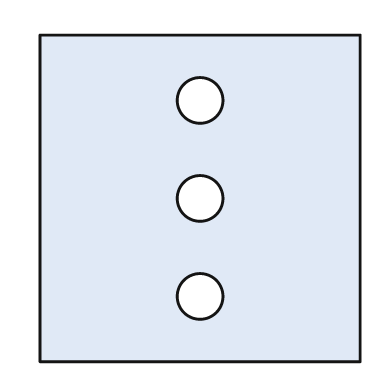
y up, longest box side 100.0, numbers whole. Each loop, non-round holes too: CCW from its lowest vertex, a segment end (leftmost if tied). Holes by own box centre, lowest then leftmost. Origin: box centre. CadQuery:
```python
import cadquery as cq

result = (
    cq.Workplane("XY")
    .moveTo(-49.0, -50.0)
    .lineTo(49.0, -50.0)
    .lineTo(49.0, 50.0)
    .lineTo(-49.0, 50.0)
    .close()
    .moveTo(0.0, -30.0)
    .circle(7.0)
    .moveTo(0.0, 0.0)
    .circle(7.0)
    .moveTo(0.0, 30.0)
    .circle(7.0)
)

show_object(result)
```